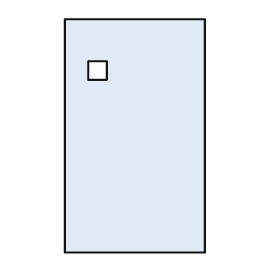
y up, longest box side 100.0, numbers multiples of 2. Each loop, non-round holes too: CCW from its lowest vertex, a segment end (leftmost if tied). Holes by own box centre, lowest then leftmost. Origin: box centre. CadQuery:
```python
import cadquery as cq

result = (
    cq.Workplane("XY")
    .moveTo(-30.0, -50.0)
    .lineTo(30.0, -50.0)
    .lineTo(30.0, 50.0)
    .lineTo(-30.0, 50.0)
    .close()
    .moveTo(-20.0, 24.0)
    .lineTo(-12.0, 24.0)
    .lineTo(-12.0, 32.0)
    .lineTo(-20.0, 32.0)
    .close()
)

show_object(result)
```